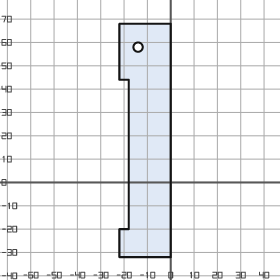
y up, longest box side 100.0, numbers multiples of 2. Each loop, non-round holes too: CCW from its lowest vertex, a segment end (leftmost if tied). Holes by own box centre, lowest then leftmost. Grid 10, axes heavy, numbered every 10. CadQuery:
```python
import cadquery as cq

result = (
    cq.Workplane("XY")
    .moveTo(-22.0, -32.0)
    .lineTo(0.0, -32.0)
    .lineTo(0.0, 68.0)
    .lineTo(-22.0, 68.0)
    .lineTo(-22.0, 44.0)
    .lineTo(-18.0, 44.0)
    .lineTo(-18.0, -20.0)
    .lineTo(-22.0, -20.0)
    .close()
    .moveTo(-14.0, 58.0)
    .circle(2.0)
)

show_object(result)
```